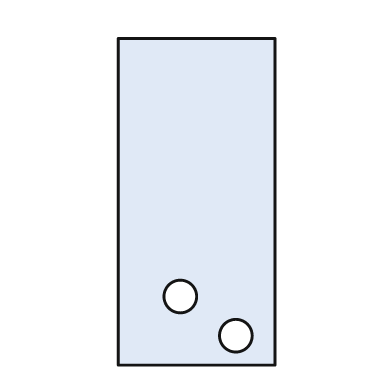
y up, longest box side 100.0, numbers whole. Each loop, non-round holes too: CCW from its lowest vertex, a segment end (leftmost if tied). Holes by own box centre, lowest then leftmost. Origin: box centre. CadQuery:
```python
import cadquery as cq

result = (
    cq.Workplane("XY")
    .moveTo(-24.0, -50.0)
    .lineTo(24.0, -50.0)
    .lineTo(24.0, 50.0)
    .lineTo(-24.0, 50.0)
    .close()
    .moveTo(12.0, -41.0)
    .circle(5.0)
    .moveTo(-5.0, -29.0)
    .circle(5.0)
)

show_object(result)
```